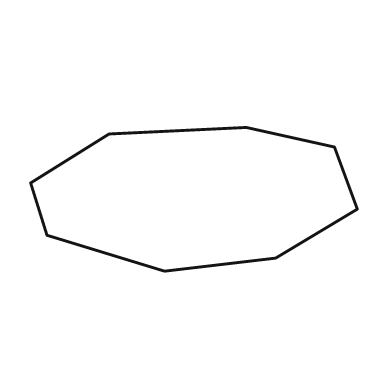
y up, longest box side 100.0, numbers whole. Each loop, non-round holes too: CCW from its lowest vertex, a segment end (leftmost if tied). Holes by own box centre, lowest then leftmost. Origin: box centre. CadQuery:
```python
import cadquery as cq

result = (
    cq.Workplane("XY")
    .moveTo(-9.0, -22.0)
    .lineTo(25.0, -18.0)
    .lineTo(50.0, -3.0)
    .lineTo(43.0, 16.0)
    .lineTo(16.0, 22.0)
    .lineTo(-26.0, 20.0)
    .lineTo(-50.0, 5.0)
    .lineTo(-45.0, -11.0)
    .close()
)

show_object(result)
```